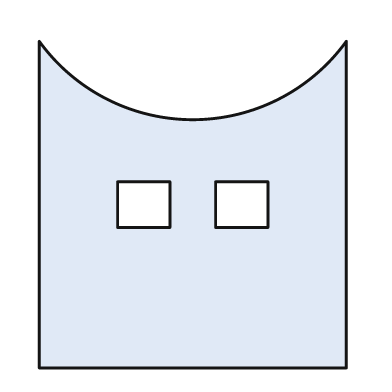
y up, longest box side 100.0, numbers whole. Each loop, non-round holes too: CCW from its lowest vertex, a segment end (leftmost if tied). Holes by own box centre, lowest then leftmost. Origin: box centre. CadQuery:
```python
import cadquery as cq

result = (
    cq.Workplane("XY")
    .moveTo(-47.0, -50.0)
    .lineTo(47.0, -50.0)
    .lineTo(47.0, 50.0)
    .threePointArc((0.0, 26.0), (-47.0, 50.0))
    .close()
    .moveTo(-23.0, -7.0)
    .lineTo(-7.0, -7.0)
    .lineTo(-7.0, 7.0)
    .lineTo(-23.0, 7.0)
    .close()
    .moveTo(7.0, -7.0)
    .lineTo(23.0, -7.0)
    .lineTo(23.0, 7.0)
    .lineTo(7.0, 7.0)
    .close()
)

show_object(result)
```